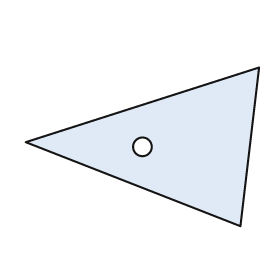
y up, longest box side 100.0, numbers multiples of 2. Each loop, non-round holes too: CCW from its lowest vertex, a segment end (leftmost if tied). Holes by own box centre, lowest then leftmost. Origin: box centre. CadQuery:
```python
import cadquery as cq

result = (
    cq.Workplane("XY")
    .moveTo(42.0, -34.0)
    .lineTo(50.0, 34.0)
    .lineTo(-50.0, 2.0)
    .close()
    .moveTo(0.0, 0.0)
    .circle(4.0)
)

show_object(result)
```